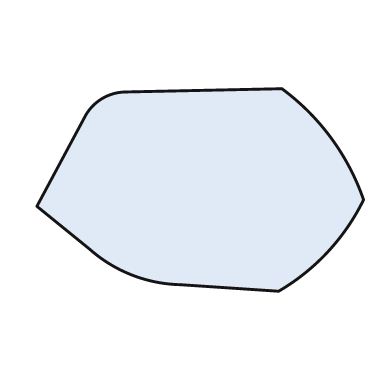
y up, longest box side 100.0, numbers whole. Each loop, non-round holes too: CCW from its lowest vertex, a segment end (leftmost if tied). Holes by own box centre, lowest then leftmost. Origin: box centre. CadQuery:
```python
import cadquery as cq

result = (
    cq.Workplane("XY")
    .moveTo(24.0, -31.0)
    .threePointArc((39.0, -19.0), (50.0, -3.0))
    .threePointArc((40.0, 16.0), (25.0, 31.0))
    .lineTo(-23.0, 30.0)
    .threePointArc((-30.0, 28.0), (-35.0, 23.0))
    .lineTo(-50.0, -5.0)
    .lineTo(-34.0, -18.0)
    .threePointArc((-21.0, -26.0), (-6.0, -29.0))
    .close()
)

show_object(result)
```